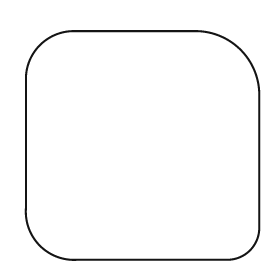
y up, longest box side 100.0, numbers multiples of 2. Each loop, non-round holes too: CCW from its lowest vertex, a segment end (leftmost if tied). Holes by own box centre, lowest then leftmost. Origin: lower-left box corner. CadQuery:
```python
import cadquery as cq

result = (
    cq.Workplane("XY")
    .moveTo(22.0, 0.0)
    .lineTo(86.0, 0.0)
    .threePointArc((96.0, 4.0), (100.0, 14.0))
    .lineTo(100.0, 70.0)
    .threePointArc((92.0, 90.0), (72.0, 98.0))
    .lineTo(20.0, 98.0)
    .threePointArc((6.0, 92.0), (0.0, 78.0))
    .lineTo(0.0, 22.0)
    .threePointArc((6.0, 6.0), (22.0, 0.0))
    .close()
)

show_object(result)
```